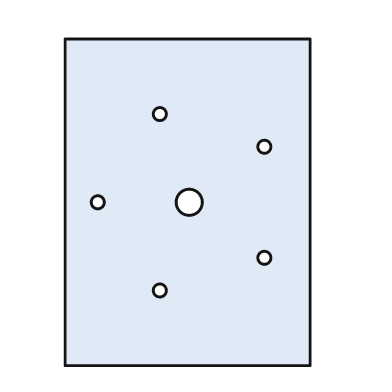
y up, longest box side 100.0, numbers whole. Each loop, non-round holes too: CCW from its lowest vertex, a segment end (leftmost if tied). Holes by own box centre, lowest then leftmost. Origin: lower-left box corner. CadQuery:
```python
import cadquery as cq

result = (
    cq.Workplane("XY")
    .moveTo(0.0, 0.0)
    .lineTo(75.0, 0.0)
    .lineTo(75.0, 100.0)
    .lineTo(0.0, 100.0)
    .close()
    .moveTo(29.0, 23.0)
    .circle(2.0)
    .moveTo(61.0, 33.0)
    .circle(2.0)
    .moveTo(10.0, 50.0)
    .circle(2.0)
    .moveTo(38.0, 50.0)
    .circle(4.0)
    .moveTo(61.0, 67.0)
    .circle(2.0)
    .moveTo(29.0, 77.0)
    .circle(2.0)
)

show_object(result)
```